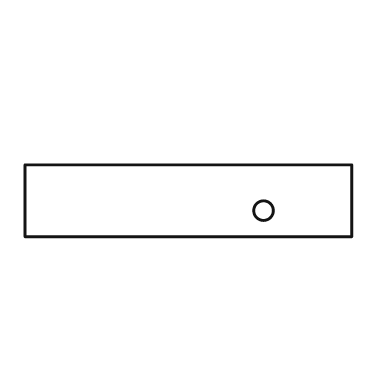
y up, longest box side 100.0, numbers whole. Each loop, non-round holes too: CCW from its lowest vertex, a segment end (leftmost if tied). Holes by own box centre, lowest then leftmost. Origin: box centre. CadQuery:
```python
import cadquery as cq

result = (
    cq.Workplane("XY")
    .moveTo(-50.0, -11.0)
    .lineTo(50.0, -11.0)
    .lineTo(50.0, 11.0)
    .lineTo(-50.0, 11.0)
    .close()
    .moveTo(23.0, -3.0)
    .circle(3.0)
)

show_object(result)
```